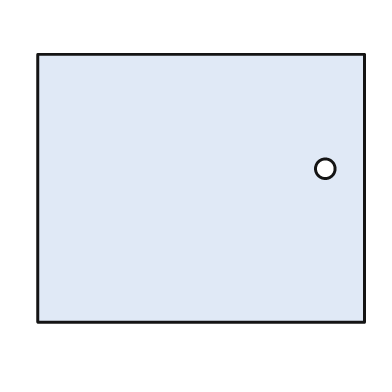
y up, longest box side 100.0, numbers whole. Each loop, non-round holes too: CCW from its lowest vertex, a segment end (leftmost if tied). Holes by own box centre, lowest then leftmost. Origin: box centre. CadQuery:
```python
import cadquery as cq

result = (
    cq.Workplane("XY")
    .moveTo(-50.0, -41.0)
    .lineTo(50.0, -41.0)
    .lineTo(50.0, 41.0)
    .lineTo(-50.0, 41.0)
    .close()
    .moveTo(38.0, 6.0)
    .circle(3.0)
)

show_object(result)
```